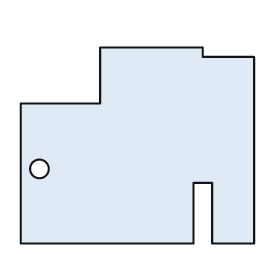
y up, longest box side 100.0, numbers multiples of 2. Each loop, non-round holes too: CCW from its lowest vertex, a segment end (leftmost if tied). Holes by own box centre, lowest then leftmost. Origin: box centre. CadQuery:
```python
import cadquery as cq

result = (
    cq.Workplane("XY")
    .moveTo(-50.0, -42.0)
    .lineTo(24.0, -42.0)
    .lineTo(24.0, -16.0)
    .lineTo(32.0, -16.0)
    .lineTo(32.0, -42.0)
    .lineTo(50.0, -42.0)
    .lineTo(50.0, 38.0)
    .lineTo(28.0, 38.0)
    .lineTo(28.0, 42.0)
    .lineTo(-16.0, 42.0)
    .lineTo(-16.0, 18.0)
    .lineTo(-50.0, 18.0)
    .close()
    .moveTo(-42.0, -10.0)
    .circle(4.0)
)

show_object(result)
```